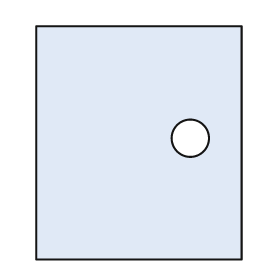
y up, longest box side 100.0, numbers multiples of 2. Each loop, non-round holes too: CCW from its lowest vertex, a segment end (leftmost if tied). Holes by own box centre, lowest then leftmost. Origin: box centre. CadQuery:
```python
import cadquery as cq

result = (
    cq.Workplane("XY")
    .moveTo(-44.0, -50.0)
    .lineTo(44.0, -50.0)
    .lineTo(44.0, 50.0)
    .lineTo(-44.0, 50.0)
    .close()
    .moveTo(22.0, 2.0)
    .circle(8.0)
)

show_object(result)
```